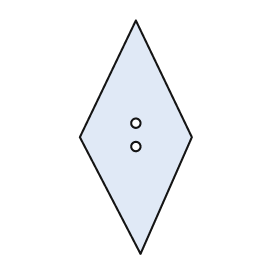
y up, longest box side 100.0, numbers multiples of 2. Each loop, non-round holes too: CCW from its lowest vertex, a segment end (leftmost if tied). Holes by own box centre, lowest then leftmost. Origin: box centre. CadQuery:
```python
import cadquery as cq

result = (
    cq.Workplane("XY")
    .moveTo(2.0, -50.0)
    .lineTo(24.0, 0.0)
    .lineTo(0.0, 50.0)
    .lineTo(-24.0, 0.0)
    .close()
    .moveTo(0.0, -4.0)
    .circle(2.0)
    .moveTo(0.0, 6.0)
    .circle(2.0)
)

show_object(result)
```